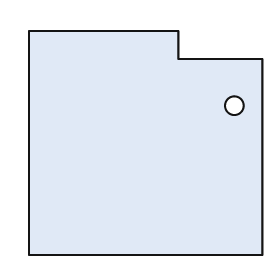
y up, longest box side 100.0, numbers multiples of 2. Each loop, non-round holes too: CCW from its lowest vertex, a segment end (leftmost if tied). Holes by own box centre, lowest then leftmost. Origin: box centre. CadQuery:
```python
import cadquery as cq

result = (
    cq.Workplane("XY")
    .moveTo(-50.0, -48.0)
    .lineTo(50.0, -48.0)
    .lineTo(50.0, 36.0)
    .lineTo(14.0, 36.0)
    .lineTo(14.0, 48.0)
    .lineTo(-50.0, 48.0)
    .close()
    .moveTo(38.0, 16.0)
    .circle(4.0)
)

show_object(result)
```